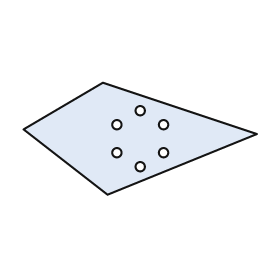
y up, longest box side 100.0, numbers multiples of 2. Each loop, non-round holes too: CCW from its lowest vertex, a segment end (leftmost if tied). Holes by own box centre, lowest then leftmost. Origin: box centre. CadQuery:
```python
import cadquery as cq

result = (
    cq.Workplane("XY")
    .moveTo(-14.0, -24.0)
    .lineTo(50.0, 2.0)
    .lineTo(-16.0, 24.0)
    .lineTo(-50.0, 4.0)
    .close()
    .moveTo(0.0, -12.0)
    .circle(2.0)
    .moveTo(-10.0, -6.0)
    .circle(2.0)
    .moveTo(10.0, -6.0)
    .circle(2.0)
    .moveTo(-10.0, 6.0)
    .circle(2.0)
    .moveTo(10.0, 6.0)
    .circle(2.0)
    .moveTo(0.0, 12.0)
    .circle(2.0)
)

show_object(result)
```